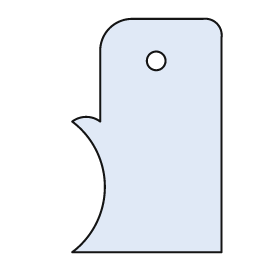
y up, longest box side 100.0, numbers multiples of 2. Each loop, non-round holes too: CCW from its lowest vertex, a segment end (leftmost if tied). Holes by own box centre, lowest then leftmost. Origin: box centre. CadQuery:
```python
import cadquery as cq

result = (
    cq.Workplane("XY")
    .moveTo(-32.0, -50.0)
    .lineTo(32.0, -50.0)
    .lineTo(32.0, 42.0)
    .threePointArc((30.0, 48.0), (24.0, 50.0))
    .lineTo(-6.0, 50.0)
    .threePointArc((-16.0, 46.0), (-20.0, 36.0))
    .lineTo(-20.0, 6.0)
    .threePointArc((-26.0, 8.0), (-32.0, 6.0))
    .threePointArc((-18.0, -22.0), (-32.0, -50.0))
    .close()
    .moveTo(4.0, 32.0)
    .circle(4.0)
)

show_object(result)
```